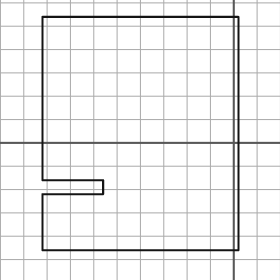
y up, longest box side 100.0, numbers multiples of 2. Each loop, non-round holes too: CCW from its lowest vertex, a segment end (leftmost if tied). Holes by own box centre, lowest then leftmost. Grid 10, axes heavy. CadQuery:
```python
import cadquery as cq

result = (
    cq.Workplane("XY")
    .moveTo(-82.0, -46.0)
    .lineTo(2.0, -46.0)
    .lineTo(2.0, 54.0)
    .lineTo(-82.0, 54.0)
    .lineTo(-82.0, -16.0)
    .lineTo(-56.0, -16.0)
    .lineTo(-56.0, -22.0)
    .lineTo(-82.0, -22.0)
    .close()
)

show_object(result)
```